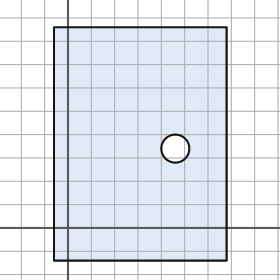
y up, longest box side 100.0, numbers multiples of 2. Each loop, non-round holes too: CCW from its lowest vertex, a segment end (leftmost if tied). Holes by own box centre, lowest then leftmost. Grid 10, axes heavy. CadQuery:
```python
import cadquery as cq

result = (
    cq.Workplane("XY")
    .moveTo(-6.0, -14.0)
    .lineTo(68.0, -14.0)
    .lineTo(68.0, 86.0)
    .lineTo(-6.0, 86.0)
    .close()
    .moveTo(46.0, 34.0)
    .circle(6.0)
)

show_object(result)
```